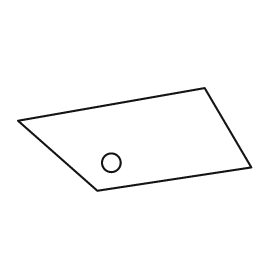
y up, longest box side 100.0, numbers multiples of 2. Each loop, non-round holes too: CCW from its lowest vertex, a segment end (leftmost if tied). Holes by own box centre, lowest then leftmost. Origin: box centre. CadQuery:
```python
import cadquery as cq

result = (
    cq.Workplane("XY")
    .moveTo(-16.0, -22.0)
    .lineTo(50.0, -12.0)
    .lineTo(30.0, 22.0)
    .lineTo(-50.0, 8.0)
    .close()
    .moveTo(-10.0, -10.0)
    .circle(4.0)
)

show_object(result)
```